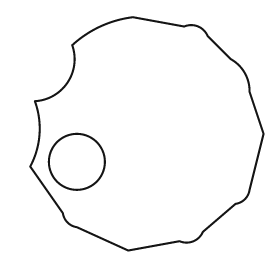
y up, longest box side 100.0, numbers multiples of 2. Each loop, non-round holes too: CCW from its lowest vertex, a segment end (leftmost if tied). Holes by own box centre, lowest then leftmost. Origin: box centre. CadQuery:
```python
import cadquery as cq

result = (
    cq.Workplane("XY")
    .moveTo(-8.0, -50.0)
    .lineTo(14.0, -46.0)
    .threePointArc((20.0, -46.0), (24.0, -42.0))
    .lineTo(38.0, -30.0)
    .threePointArc((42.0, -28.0), (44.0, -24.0))
    .lineTo(50.0, 0.0)
    .lineTo(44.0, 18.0)
    .threePointArc((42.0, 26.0), (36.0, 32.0))
    .lineTo(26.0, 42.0)
    .threePointArc((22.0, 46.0), (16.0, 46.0))
    .lineTo(-6.0, 50.0)
    .threePointArc((-20.0, 46.0), (-32.0, 38.0))
    .threePointArc((-34.0, 22.0), (-48.0, 14.0))
    .threePointArc((-46.0, 0.0), (-50.0, -14.0))
    .lineTo(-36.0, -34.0)
    .threePointArc((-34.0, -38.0), (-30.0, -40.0))
    .close()
    .moveTo(-30.0, -12.0)
    .circle(12.0)
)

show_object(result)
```